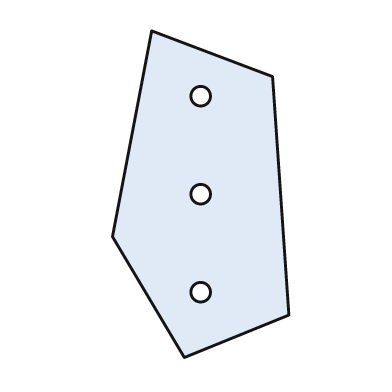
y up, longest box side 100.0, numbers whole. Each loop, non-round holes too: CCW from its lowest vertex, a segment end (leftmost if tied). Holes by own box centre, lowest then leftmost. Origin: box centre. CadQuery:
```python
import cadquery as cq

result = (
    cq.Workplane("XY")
    .moveTo(-5.0, -50.0)
    .lineTo(27.0, -37.0)
    .lineTo(22.0, 36.0)
    .lineTo(-15.0, 50.0)
    .lineTo(-27.0, -13.0)
    .close()
    .moveTo(0.0, -30.0)
    .circle(3.0)
    .moveTo(0.0, 0.0)
    .circle(3.0)
    .moveTo(0.0, 30.0)
    .circle(3.0)
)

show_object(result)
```